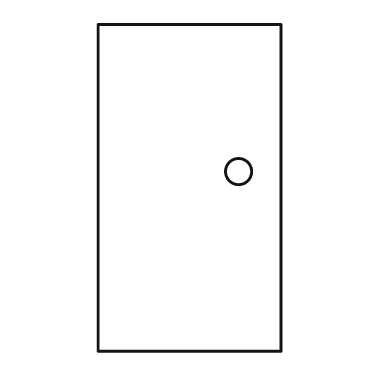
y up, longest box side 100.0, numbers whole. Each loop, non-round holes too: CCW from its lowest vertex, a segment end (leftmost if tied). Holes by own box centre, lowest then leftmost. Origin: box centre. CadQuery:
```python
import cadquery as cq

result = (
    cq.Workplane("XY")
    .moveTo(-28.0, -50.0)
    .lineTo(28.0, -50.0)
    .lineTo(28.0, 50.0)
    .lineTo(-28.0, 50.0)
    .close()
    .moveTo(15.0, 5.0)
    .circle(4.0)
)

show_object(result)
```